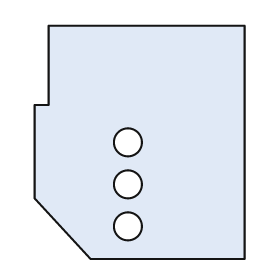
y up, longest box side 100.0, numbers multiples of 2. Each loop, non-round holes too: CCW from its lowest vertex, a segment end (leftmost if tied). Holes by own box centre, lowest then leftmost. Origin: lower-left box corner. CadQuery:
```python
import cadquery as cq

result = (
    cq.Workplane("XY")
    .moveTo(24.0, 0.0)
    .lineTo(90.0, 0.0)
    .lineTo(90.0, 100.0)
    .lineTo(6.0, 100.0)
    .lineTo(6.0, 66.0)
    .lineTo(0.0, 66.0)
    .lineTo(0.0, 26.0)
    .close()
    .moveTo(40.0, 14.0)
    .circle(6.0)
    .moveTo(40.0, 32.0)
    .circle(6.0)
    .moveTo(40.0, 50.0)
    .circle(6.0)
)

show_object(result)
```